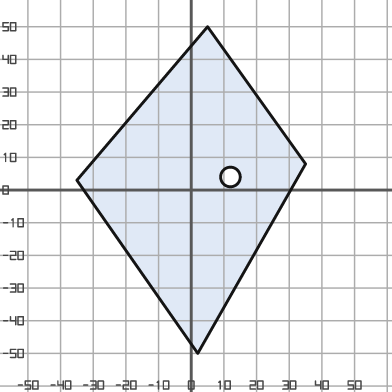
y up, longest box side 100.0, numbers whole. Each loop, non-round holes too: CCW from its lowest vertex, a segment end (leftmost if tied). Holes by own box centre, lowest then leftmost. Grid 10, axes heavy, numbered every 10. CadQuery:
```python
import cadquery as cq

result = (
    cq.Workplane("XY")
    .moveTo(2.0, -50.0)
    .lineTo(35.0, 8.0)
    .lineTo(5.0, 50.0)
    .lineTo(-35.0, 3.0)
    .close()
    .moveTo(12.0, 4.0)
    .circle(3.0)
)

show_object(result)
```